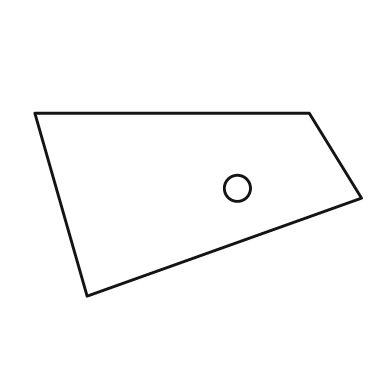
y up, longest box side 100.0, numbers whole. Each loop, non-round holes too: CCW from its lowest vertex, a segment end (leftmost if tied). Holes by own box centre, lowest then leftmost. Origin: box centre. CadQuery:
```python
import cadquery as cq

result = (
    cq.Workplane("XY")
    .moveTo(-34.0, -28.0)
    .lineTo(50.0, 2.0)
    .lineTo(34.0, 28.0)
    .lineTo(-50.0, 28.0)
    .close()
    .moveTo(12.0, 5.0)
    .circle(4.0)
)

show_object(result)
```